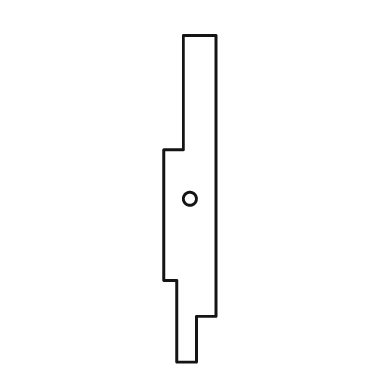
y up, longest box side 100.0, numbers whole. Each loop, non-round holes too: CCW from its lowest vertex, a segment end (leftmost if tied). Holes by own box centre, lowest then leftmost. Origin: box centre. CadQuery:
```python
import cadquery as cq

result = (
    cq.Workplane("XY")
    .moveTo(-4.0, -50.0)
    .lineTo(2.0, -50.0)
    .lineTo(2.0, -36.0)
    .lineTo(8.0, -36.0)
    .lineTo(8.0, 50.0)
    .lineTo(-2.0, 50.0)
    .lineTo(-2.0, 15.0)
    .lineTo(-8.0, 15.0)
    .lineTo(-8.0, -25.0)
    .lineTo(-4.0, -25.0)
    .close()
    .moveTo(0.0, 0.0)
    .circle(2.0)
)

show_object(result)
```